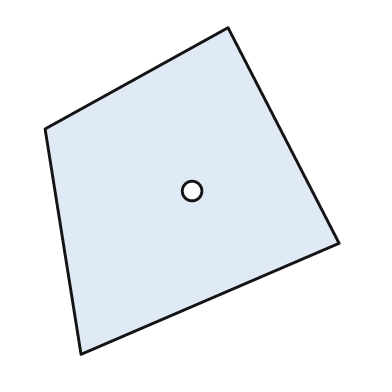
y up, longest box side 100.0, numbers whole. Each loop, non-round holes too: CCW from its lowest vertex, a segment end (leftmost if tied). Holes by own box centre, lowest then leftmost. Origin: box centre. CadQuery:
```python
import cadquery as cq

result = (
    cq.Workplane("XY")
    .moveTo(-34.0, -50.0)
    .lineTo(45.0, -16.0)
    .lineTo(11.0, 50.0)
    .lineTo(-45.0, 19.0)
    .close()
    .moveTo(0.0, 0.0)
    .circle(3.0)
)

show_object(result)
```